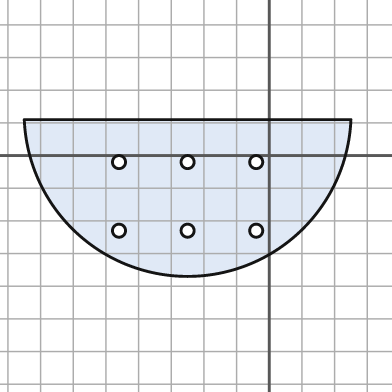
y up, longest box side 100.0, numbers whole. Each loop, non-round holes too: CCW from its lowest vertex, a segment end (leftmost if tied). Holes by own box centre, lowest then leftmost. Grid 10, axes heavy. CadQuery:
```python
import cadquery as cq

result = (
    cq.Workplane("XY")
    .moveTo(-75.0, 11.0)
    .threePointArc((-25.0, -37.0), (25.0, 11.0))
    .close()
    .moveTo(-46.0, -23.0)
    .circle(2.0)
    .moveTo(-25.0, -23.0)
    .circle(2.0)
    .moveTo(-4.0, -23.0)
    .circle(2.0)
    .moveTo(-46.0, -2.0)
    .circle(2.0)
    .moveTo(-25.0, -2.0)
    .circle(2.0)
    .moveTo(-4.0, -2.0)
    .circle(2.0)
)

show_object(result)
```